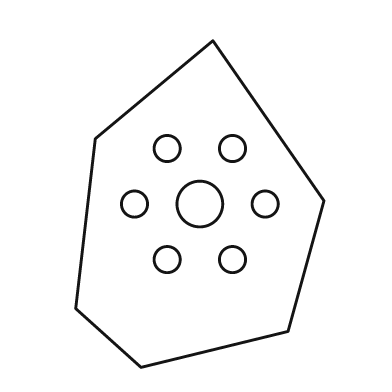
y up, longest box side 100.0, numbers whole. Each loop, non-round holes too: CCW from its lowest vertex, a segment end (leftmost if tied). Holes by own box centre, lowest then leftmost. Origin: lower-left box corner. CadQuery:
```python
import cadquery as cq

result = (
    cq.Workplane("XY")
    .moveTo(20.0, 0.0)
    .lineTo(65.0, 11.0)
    .lineTo(76.0, 51.0)
    .lineTo(42.0, 100.0)
    .lineTo(6.0, 70.0)
    .lineTo(0.0, 18.0)
    .close()
    .moveTo(28.0, 33.0)
    .circle(4.0)
    .moveTo(48.0, 33.0)
    .circle(4.0)
    .moveTo(18.0, 50.0)
    .circle(4.0)
    .moveTo(38.0, 50.0)
    .circle(7.0)
    .moveTo(58.0, 50.0)
    .circle(4.0)
    .moveTo(28.0, 67.0)
    .circle(4.0)
    .moveTo(48.0, 67.0)
    .circle(4.0)
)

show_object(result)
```